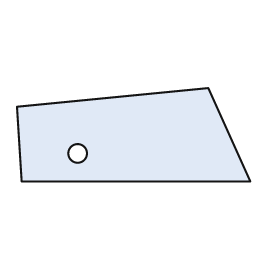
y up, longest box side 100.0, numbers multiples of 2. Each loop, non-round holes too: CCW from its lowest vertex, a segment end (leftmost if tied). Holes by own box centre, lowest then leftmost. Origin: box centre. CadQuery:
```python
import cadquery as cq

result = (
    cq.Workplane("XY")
    .moveTo(-48.0, -20.0)
    .lineTo(50.0, -20.0)
    .lineTo(32.0, 20.0)
    .lineTo(-50.0, 12.0)
    .close()
    .moveTo(-24.0, -8.0)
    .circle(4.0)
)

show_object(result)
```